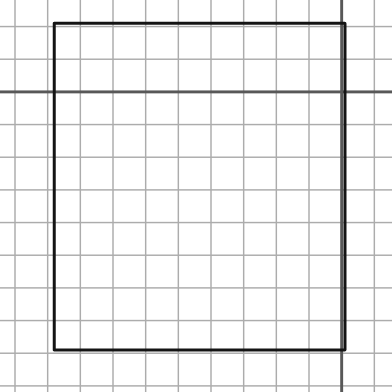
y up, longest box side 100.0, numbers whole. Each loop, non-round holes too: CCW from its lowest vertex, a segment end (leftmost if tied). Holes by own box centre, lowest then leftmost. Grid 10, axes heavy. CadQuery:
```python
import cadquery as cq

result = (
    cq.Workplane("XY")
    .moveTo(-88.0, -79.0)
    .lineTo(1.0, -79.0)
    .lineTo(1.0, 21.0)
    .lineTo(-88.0, 21.0)
    .close()
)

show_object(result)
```